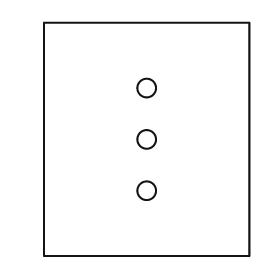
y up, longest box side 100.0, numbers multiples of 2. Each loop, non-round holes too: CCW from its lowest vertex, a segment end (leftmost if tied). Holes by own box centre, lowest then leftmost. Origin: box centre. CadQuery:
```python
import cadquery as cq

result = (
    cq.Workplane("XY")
    .moveTo(-44.0, -50.0)
    .lineTo(44.0, -50.0)
    .lineTo(44.0, 50.0)
    .lineTo(-44.0, 50.0)
    .close()
    .moveTo(0.0, -22.0)
    .circle(4.0)
    .moveTo(0.0, 0.0)
    .circle(4.0)
    .moveTo(0.0, 22.0)
    .circle(4.0)
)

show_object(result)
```